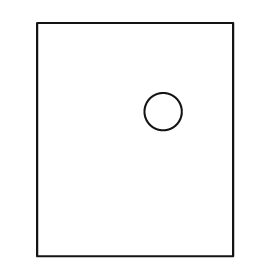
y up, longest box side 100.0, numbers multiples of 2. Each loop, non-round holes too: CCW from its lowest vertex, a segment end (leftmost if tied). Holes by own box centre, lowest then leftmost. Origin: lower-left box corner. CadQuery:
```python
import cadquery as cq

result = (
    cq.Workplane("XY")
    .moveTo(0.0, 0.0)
    .lineTo(84.0, 0.0)
    .lineTo(84.0, 100.0)
    .lineTo(0.0, 100.0)
    .close()
    .moveTo(54.0, 62.0)
    .circle(8.0)
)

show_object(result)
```